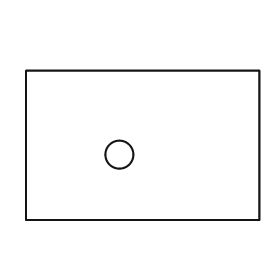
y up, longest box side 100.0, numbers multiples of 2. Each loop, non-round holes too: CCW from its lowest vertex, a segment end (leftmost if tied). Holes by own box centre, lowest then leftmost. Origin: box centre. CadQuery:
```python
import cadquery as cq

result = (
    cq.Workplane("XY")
    .moveTo(-50.0, -32.0)
    .lineTo(50.0, -32.0)
    .lineTo(50.0, 32.0)
    .lineTo(-50.0, 32.0)
    .close()
    .moveTo(-10.0, -4.0)
    .circle(6.0)
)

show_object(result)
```